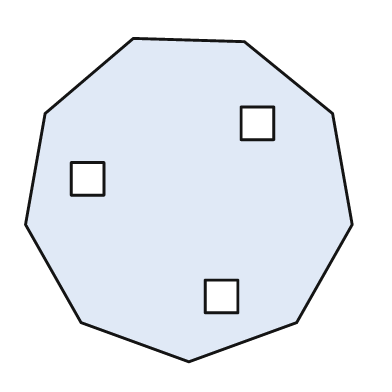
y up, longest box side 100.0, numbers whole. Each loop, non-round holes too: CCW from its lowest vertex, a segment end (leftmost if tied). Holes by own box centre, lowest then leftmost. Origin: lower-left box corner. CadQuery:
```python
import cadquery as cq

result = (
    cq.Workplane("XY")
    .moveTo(50.0, 0.0)
    .lineTo(83.0, 12.0)
    .lineTo(100.0, 42.0)
    .lineTo(94.0, 76.0)
    .lineTo(67.0, 98.0)
    .lineTo(33.0, 99.0)
    .lineTo(6.0, 76.0)
    .lineTo(0.0, 42.0)
    .lineTo(17.0, 12.0)
    .close()
    .moveTo(55.0, 15.0)
    .lineTo(65.0, 15.0)
    .lineTo(65.0, 25.0)
    .lineTo(55.0, 25.0)
    .close()
    .moveTo(14.0, 51.0)
    .lineTo(24.0, 51.0)
    .lineTo(24.0, 61.0)
    .lineTo(14.0, 61.0)
    .close()
    .moveTo(66.0, 68.0)
    .lineTo(76.0, 68.0)
    .lineTo(76.0, 78.0)
    .lineTo(66.0, 78.0)
    .close()
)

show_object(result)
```